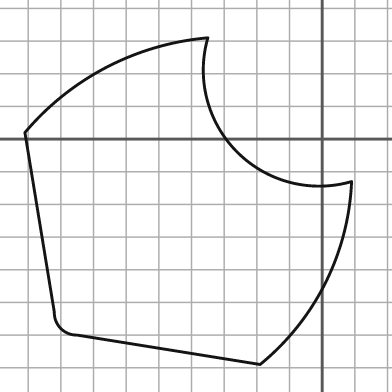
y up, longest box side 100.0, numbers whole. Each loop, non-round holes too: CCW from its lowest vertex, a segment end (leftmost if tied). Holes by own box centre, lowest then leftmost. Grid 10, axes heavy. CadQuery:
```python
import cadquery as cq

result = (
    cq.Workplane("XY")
    .moveTo(-19.0, -69.0)
    .threePointArc((1.0, -44.0), (9.0, -13.0))
    .threePointArc((-26.0, -4.0), (-35.0, 31.0))
    .threePointArc((-66.0, 22.0), (-91.0, 2.0))
    .lineTo(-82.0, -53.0)
    .threePointArc((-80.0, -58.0), (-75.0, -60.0))
    .close()
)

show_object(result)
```